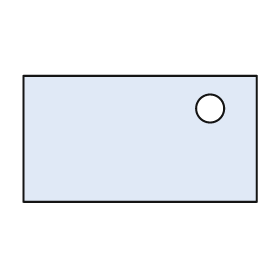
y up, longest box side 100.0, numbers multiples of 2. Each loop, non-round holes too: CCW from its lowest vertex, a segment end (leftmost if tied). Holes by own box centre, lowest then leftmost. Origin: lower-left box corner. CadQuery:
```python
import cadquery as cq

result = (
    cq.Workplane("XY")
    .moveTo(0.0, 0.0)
    .lineTo(100.0, 0.0)
    .lineTo(100.0, 54.0)
    .lineTo(0.0, 54.0)
    .close()
    .moveTo(80.0, 40.0)
    .circle(6.0)
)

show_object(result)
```